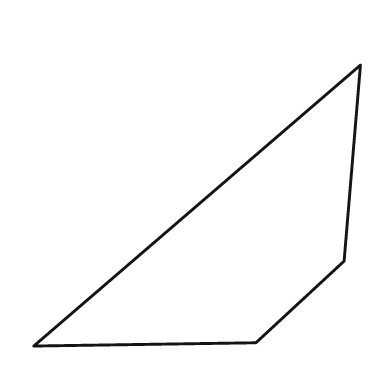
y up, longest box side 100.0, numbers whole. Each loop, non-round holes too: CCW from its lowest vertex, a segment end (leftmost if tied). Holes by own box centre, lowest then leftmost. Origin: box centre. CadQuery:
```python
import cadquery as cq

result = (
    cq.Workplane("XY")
    .moveTo(-50.0, -43.0)
    .lineTo(18.0, -42.0)
    .lineTo(45.0, -17.0)
    .lineTo(50.0, 43.0)
    .close()
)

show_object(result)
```